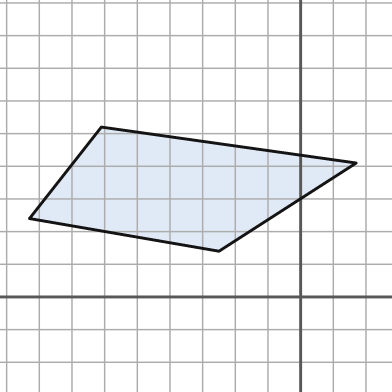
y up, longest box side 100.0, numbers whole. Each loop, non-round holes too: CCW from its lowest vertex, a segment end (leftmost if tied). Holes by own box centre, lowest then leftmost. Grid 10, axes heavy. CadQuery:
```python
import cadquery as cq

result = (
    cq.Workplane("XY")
    .moveTo(-25.0, 14.0)
    .lineTo(17.0, 41.0)
    .lineTo(-61.0, 52.0)
    .lineTo(-83.0, 24.0)
    .close()
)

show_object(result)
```